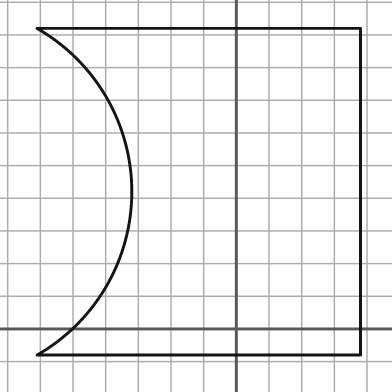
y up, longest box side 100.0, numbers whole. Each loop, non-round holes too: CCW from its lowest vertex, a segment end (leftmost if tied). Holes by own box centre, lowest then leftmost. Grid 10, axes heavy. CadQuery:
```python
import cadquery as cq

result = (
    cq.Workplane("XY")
    .moveTo(-61.0, -8.0)
    .lineTo(38.0, -8.0)
    .lineTo(38.0, 92.0)
    .lineTo(-61.0, 92.0)
    .threePointArc((-32.0, 42.0), (-61.0, -8.0))
    .close()
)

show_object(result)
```